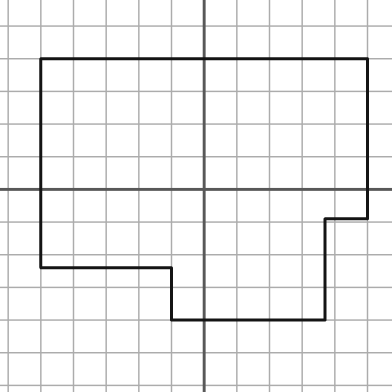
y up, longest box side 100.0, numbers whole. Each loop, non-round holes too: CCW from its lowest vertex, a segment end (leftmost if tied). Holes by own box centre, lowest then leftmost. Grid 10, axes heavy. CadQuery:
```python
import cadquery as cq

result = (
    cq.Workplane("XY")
    .moveTo(-10.0, -40.0)
    .lineTo(37.0, -40.0)
    .lineTo(37.0, -9.0)
    .lineTo(50.0, -9.0)
    .lineTo(50.0, 40.0)
    .lineTo(-50.0, 40.0)
    .lineTo(-50.0, -24.0)
    .lineTo(-10.0, -24.0)
    .close()
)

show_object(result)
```